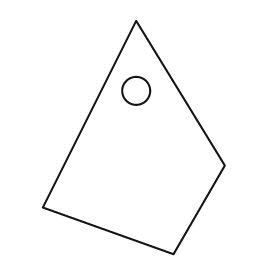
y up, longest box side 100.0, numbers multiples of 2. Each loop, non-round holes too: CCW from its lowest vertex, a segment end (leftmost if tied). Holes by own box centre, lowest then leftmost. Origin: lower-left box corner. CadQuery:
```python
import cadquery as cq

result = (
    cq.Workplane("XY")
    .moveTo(56.0, 0.0)
    .lineTo(78.0, 38.0)
    .lineTo(40.0, 100.0)
    .lineTo(0.0, 20.0)
    .close()
    .moveTo(40.0, 70.0)
    .circle(6.0)
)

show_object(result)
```